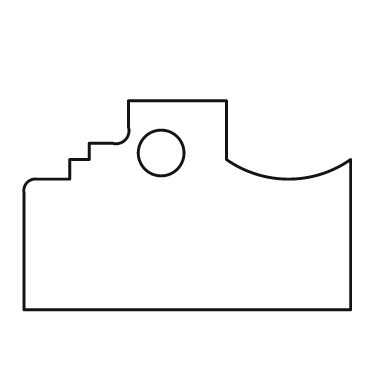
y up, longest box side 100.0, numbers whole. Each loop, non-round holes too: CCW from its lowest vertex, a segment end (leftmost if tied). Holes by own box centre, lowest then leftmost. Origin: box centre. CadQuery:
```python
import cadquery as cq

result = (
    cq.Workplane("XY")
    .moveTo(-50.0, -32.0)
    .lineTo(50.0, -32.0)
    .lineTo(50.0, 14.0)
    .threePointArc((31.0, 8.0), (12.0, 14.0))
    .lineTo(12.0, 32.0)
    .lineTo(-18.0, 32.0)
    .lineTo(-18.0, 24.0)
    .threePointArc((-19.0, 20.0), (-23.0, 19.0))
    .lineTo(-30.0, 19.0)
    .lineTo(-30.0, 14.0)
    .lineTo(-36.0, 14.0)
    .lineTo(-36.0, 8.0)
    .lineTo(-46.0, 8.0)
    .threePointArc((-49.0, 7.0), (-50.0, 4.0))
    .close()
    .moveTo(-8.0, 16.0)
    .circle(7.0)
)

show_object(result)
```